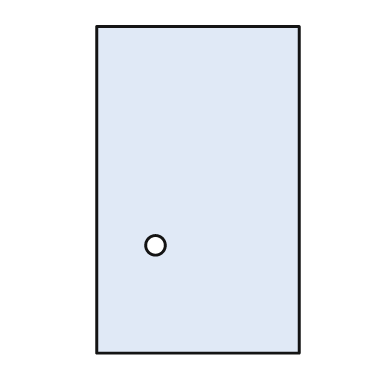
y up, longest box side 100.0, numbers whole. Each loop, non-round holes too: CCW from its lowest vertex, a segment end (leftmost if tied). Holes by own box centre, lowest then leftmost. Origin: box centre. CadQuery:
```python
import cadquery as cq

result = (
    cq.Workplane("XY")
    .moveTo(-31.0, -50.0)
    .lineTo(31.0, -50.0)
    .lineTo(31.0, 50.0)
    .lineTo(-31.0, 50.0)
    .close()
    .moveTo(-13.0, -17.0)
    .circle(3.0)
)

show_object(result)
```